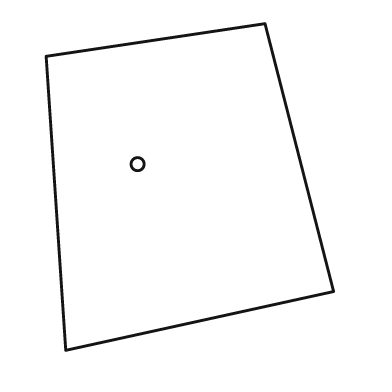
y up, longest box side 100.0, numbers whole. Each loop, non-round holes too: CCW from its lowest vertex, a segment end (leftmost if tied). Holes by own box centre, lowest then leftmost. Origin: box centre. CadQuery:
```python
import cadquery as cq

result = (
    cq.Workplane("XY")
    .moveTo(-38.0, -50.0)
    .lineTo(44.0, -32.0)
    .lineTo(23.0, 50.0)
    .lineTo(-44.0, 40.0)
    .close()
    .moveTo(-16.0, 7.0)
    .circle(2.0)
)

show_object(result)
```